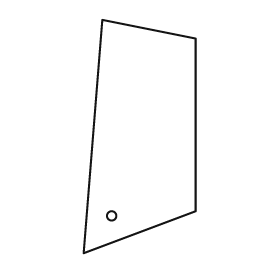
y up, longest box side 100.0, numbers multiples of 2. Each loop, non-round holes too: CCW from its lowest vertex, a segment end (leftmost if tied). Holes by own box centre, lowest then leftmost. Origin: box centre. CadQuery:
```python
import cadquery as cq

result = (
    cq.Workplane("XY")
    .moveTo(-24.0, -50.0)
    .lineTo(24.0, -32.0)
    .lineTo(24.0, 42.0)
    .lineTo(-16.0, 50.0)
    .close()
    .moveTo(-12.0, -34.0)
    .circle(2.0)
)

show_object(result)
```